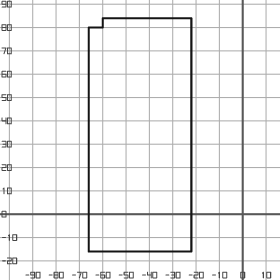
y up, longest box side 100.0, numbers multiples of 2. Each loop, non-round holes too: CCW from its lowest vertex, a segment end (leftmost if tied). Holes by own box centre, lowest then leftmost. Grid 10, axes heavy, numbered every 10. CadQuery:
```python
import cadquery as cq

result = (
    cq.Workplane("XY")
    .moveTo(-66.0, -16.0)
    .lineTo(-22.0, -16.0)
    .lineTo(-22.0, 84.0)
    .lineTo(-60.0, 84.0)
    .lineTo(-60.0, 80.0)
    .lineTo(-66.0, 80.0)
    .close()
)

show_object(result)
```